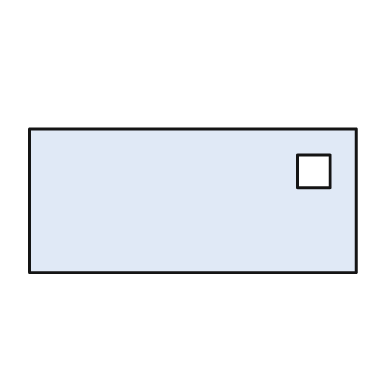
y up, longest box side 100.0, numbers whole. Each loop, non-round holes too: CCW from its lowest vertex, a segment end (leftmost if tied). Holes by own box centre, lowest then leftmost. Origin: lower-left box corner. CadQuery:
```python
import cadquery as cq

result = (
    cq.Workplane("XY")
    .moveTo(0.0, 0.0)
    .lineTo(100.0, 0.0)
    .lineTo(100.0, 44.0)
    .lineTo(0.0, 44.0)
    .close()
    .moveTo(82.0, 26.0)
    .lineTo(92.0, 26.0)
    .lineTo(92.0, 36.0)
    .lineTo(82.0, 36.0)
    .close()
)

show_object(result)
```